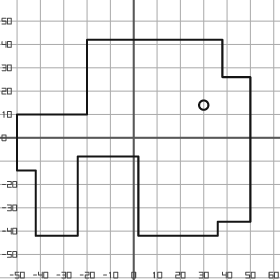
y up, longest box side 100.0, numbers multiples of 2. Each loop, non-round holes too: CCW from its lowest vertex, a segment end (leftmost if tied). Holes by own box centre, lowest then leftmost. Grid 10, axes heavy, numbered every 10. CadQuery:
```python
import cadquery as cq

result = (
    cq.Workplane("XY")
    .moveTo(-42.0, -42.0)
    .lineTo(-24.0, -42.0)
    .lineTo(-24.0, -8.0)
    .lineTo(2.0, -8.0)
    .lineTo(2.0, -42.0)
    .lineTo(36.0, -42.0)
    .lineTo(36.0, -36.0)
    .lineTo(50.0, -36.0)
    .lineTo(50.0, 26.0)
    .lineTo(38.0, 26.0)
    .lineTo(38.0, 42.0)
    .lineTo(-20.0, 42.0)
    .lineTo(-20.0, 10.0)
    .lineTo(-50.0, 10.0)
    .lineTo(-50.0, -14.0)
    .lineTo(-42.0, -14.0)
    .close()
    .moveTo(30.0, 14.0)
    .circle(2.0)
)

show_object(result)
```